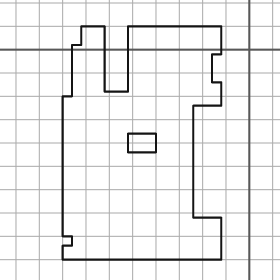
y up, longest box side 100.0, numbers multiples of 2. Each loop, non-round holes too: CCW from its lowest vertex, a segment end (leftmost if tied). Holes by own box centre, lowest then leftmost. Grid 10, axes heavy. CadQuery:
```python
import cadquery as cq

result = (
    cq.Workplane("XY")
    .moveTo(-80.0, -90.0)
    .lineTo(-12.0, -90.0)
    .lineTo(-12.0, -72.0)
    .lineTo(-24.0, -72.0)
    .lineTo(-24.0, -24.0)
    .lineTo(-12.0, -24.0)
    .lineTo(-12.0, -14.0)
    .lineTo(-16.0, -14.0)
    .lineTo(-16.0, -2.0)
    .lineTo(-12.0, -2.0)
    .lineTo(-12.0, 10.0)
    .lineTo(-52.0, 10.0)
    .lineTo(-52.0, -18.0)
    .lineTo(-62.0, -18.0)
    .lineTo(-62.0, 10.0)
    .lineTo(-72.0, 10.0)
    .lineTo(-72.0, 2.0)
    .lineTo(-76.0, 2.0)
    .lineTo(-76.0, -20.0)
    .lineTo(-80.0, -20.0)
    .lineTo(-80.0, -80.0)
    .lineTo(-76.0, -80.0)
    .lineTo(-76.0, -84.0)
    .lineTo(-80.0, -84.0)
    .close()
    .moveTo(-52.0, -44.0)
    .lineTo(-40.0, -44.0)
    .lineTo(-40.0, -36.0)
    .lineTo(-52.0, -36.0)
    .close()
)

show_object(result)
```